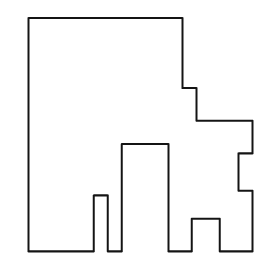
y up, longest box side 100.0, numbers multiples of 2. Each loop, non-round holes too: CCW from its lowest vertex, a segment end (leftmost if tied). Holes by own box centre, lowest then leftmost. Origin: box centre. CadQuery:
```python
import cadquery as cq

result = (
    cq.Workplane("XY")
    .moveTo(-48.0, -50.0)
    .lineTo(-20.0, -50.0)
    .lineTo(-20.0, -26.0)
    .lineTo(-14.0, -26.0)
    .lineTo(-14.0, -50.0)
    .lineTo(-8.0, -50.0)
    .lineTo(-8.0, -4.0)
    .lineTo(12.0, -4.0)
    .lineTo(12.0, -50.0)
    .lineTo(22.0, -50.0)
    .lineTo(22.0, -36.0)
    .lineTo(34.0, -36.0)
    .lineTo(34.0, -50.0)
    .lineTo(48.0, -50.0)
    .lineTo(48.0, -24.0)
    .lineTo(42.0, -24.0)
    .lineTo(42.0, -8.0)
    .lineTo(48.0, -8.0)
    .lineTo(48.0, 6.0)
    .lineTo(24.0, 6.0)
    .lineTo(24.0, 20.0)
    .lineTo(18.0, 20.0)
    .lineTo(18.0, 50.0)
    .lineTo(-48.0, 50.0)
    .close()
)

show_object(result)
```